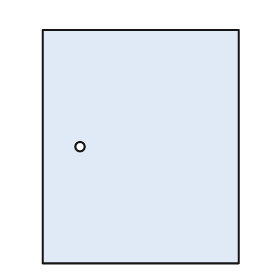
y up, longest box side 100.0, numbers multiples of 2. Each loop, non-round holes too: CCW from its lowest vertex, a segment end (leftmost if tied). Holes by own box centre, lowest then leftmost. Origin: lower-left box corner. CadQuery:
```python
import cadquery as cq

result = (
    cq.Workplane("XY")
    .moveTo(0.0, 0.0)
    .lineTo(84.0, 0.0)
    .lineTo(84.0, 100.0)
    .lineTo(0.0, 100.0)
    .close()
    .moveTo(16.0, 50.0)
    .circle(2.0)
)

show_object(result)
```